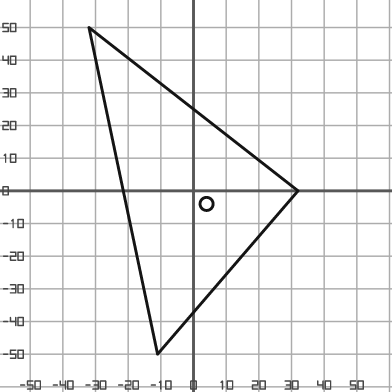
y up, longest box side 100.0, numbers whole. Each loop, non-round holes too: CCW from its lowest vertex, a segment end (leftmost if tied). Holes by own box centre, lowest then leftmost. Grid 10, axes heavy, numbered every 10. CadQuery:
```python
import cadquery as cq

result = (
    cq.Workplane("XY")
    .moveTo(-11.0, -50.0)
    .lineTo(32.0, 0.0)
    .lineTo(-32.0, 50.0)
    .close()
    .moveTo(4.0, -4.0)
    .circle(2.0)
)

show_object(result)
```